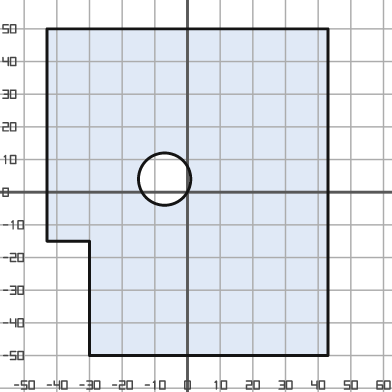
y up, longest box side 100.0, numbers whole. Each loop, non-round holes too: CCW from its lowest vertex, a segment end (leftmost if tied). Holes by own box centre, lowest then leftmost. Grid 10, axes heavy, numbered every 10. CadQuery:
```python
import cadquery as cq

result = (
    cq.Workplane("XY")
    .moveTo(-30.0, -50.0)
    .lineTo(43.0, -50.0)
    .lineTo(43.0, 50.0)
    .lineTo(-43.0, 50.0)
    .lineTo(-43.0, -15.0)
    .lineTo(-30.0, -15.0)
    .close()
    .moveTo(-7.0, 4.0)
    .circle(8.0)
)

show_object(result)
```